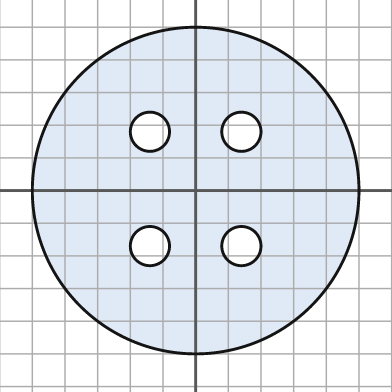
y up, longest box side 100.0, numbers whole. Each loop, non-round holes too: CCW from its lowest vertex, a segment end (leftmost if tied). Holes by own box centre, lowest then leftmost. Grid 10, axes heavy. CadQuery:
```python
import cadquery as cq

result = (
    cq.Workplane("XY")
    .moveTo(0.0, 0.0)
    .circle(50.0)
    .moveTo(-14.0, -17.0)
    .circle(6.0)
    .moveTo(14.0, -17.0)
    .circle(6.0)
    .moveTo(-14.0, 18.0)
    .circle(6.0)
    .moveTo(14.0, 18.0)
    .circle(6.0)
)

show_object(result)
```